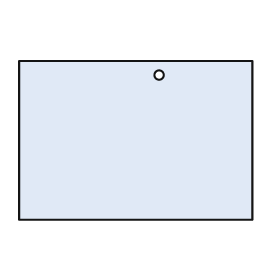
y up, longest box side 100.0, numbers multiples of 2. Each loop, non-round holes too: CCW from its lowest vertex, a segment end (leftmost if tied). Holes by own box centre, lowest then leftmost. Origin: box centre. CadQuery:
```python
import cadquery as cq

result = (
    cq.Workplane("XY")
    .moveTo(-50.0, -34.0)
    .lineTo(50.0, -34.0)
    .lineTo(50.0, 34.0)
    .lineTo(-50.0, 34.0)
    .close()
    .moveTo(10.0, 28.0)
    .circle(2.0)
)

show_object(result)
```